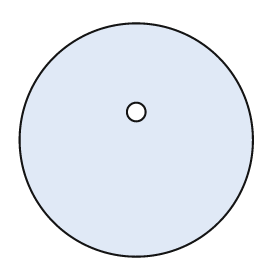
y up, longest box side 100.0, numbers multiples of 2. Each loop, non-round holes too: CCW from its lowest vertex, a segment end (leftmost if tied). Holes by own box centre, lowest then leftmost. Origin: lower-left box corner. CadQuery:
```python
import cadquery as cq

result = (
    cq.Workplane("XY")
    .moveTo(50.0, 50.0)
    .circle(50.0)
    .moveTo(50.0, 62.0)
    .circle(4.0)
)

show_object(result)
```